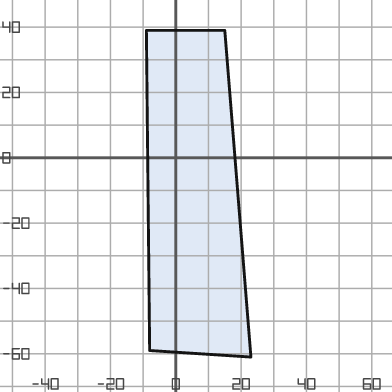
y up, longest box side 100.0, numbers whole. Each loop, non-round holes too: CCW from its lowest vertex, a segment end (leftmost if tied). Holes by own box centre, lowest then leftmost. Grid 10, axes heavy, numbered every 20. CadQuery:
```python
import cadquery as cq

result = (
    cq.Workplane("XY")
    .moveTo(23.0, -61.0)
    .lineTo(15.0, 39.0)
    .lineTo(-9.0, 39.0)
    .lineTo(-8.0, -59.0)
    .close()
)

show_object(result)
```